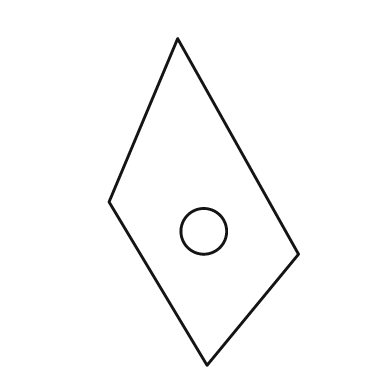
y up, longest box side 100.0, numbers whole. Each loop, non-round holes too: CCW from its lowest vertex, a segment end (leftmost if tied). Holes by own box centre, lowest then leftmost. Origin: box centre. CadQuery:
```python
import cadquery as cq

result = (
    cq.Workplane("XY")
    .moveTo(1.0, -50.0)
    .lineTo(29.0, -16.0)
    .lineTo(-8.0, 50.0)
    .lineTo(-29.0, 0.0)
    .close()
    .moveTo(0.0, -9.0)
    .circle(7.0)
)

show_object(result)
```